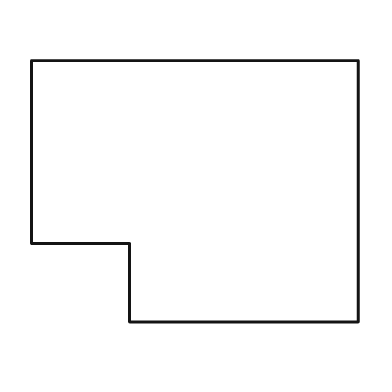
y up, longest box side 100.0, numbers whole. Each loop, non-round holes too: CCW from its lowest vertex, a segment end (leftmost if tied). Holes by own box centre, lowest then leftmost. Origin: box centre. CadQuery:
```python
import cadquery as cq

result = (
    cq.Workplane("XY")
    .moveTo(-20.0, -40.0)
    .lineTo(50.0, -40.0)
    .lineTo(50.0, 40.0)
    .lineTo(-50.0, 40.0)
    .lineTo(-50.0, -16.0)
    .lineTo(-20.0, -16.0)
    .close()
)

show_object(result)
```